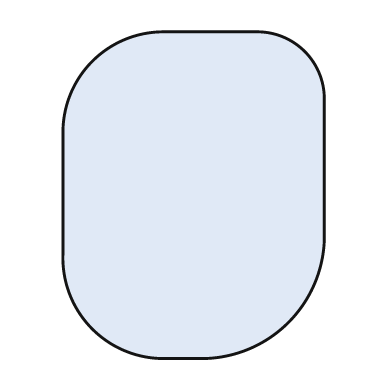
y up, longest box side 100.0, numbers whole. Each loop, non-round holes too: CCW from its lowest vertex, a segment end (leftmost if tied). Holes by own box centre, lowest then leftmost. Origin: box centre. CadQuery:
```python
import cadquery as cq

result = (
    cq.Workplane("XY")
    .moveTo(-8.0, -50.0)
    .lineTo(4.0, -50.0)
    .threePointArc((29.0, -39.0), (40.0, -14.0))
    .lineTo(40.0, 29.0)
    .threePointArc((34.0, 44.0), (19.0, 50.0))
    .lineTo(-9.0, 50.0)
    .threePointArc((-31.0, 41.0), (-40.0, 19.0))
    .lineTo(-40.0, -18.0)
    .threePointArc((-31.0, -41.0), (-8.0, -50.0))
    .close()
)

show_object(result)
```